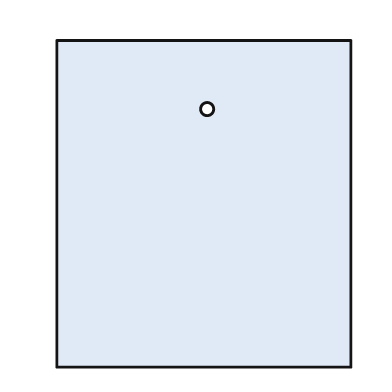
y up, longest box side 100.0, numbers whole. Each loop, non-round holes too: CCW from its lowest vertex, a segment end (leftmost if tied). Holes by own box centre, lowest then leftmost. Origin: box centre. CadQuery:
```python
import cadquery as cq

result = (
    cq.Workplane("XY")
    .moveTo(-45.0, -50.0)
    .lineTo(45.0, -50.0)
    .lineTo(45.0, 50.0)
    .lineTo(-45.0, 50.0)
    .close()
    .moveTo(1.0, 29.0)
    .circle(2.0)
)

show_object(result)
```